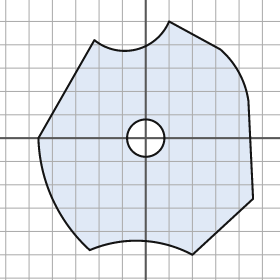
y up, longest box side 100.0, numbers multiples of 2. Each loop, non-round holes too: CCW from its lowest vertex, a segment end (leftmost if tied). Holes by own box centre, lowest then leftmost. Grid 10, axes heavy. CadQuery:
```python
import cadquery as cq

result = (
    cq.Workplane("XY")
    .moveTo(20.0, -50.0)
    .lineTo(46.0, -26.0)
    .lineTo(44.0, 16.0)
    .threePointArc((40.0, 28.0), (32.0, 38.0))
    .lineTo(10.0, 50.0)
    .threePointArc((-4.0, 38.0), (-22.0, 42.0))
    .lineTo(-46.0, 0.0)
    .threePointArc((-40.0, -26.0), (-24.0, -48.0))
    .threePointArc((-2.0, -44.0), (20.0, -50.0))
    .close()
    .moveTo(0.0, 0.0)
    .circle(8.0)
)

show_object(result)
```